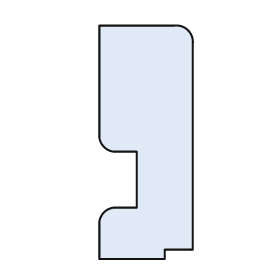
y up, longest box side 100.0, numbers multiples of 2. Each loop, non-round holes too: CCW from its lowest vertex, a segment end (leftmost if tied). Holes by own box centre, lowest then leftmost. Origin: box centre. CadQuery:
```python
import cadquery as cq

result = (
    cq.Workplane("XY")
    .moveTo(-20.0, -50.0)
    .lineTo(8.0, -50.0)
    .lineTo(8.0, -46.0)
    .lineTo(20.0, -46.0)
    .lineTo(20.0, 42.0)
    .threePointArc((18.0, 48.0), (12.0, 50.0))
    .lineTo(-20.0, 50.0)
    .lineTo(-20.0, 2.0)
    .threePointArc((-18.0, -2.0), (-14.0, -4.0))
    .lineTo(-4.0, -4.0)
    .lineTo(-4.0, -28.0)
    .lineTo(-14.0, -28.0)
    .threePointArc((-18.0, -30.0), (-20.0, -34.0))
    .close()
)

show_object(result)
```